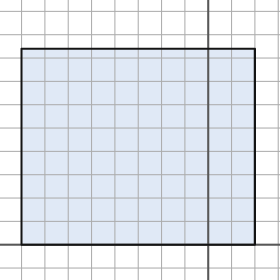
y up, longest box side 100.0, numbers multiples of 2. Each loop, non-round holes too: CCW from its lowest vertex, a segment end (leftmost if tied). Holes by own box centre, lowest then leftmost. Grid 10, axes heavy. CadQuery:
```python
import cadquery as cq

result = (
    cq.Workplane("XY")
    .moveTo(-80.0, 0.0)
    .lineTo(20.0, 0.0)
    .lineTo(20.0, 84.0)
    .lineTo(-80.0, 84.0)
    .close()
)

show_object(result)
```